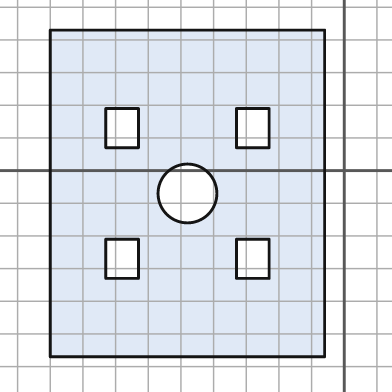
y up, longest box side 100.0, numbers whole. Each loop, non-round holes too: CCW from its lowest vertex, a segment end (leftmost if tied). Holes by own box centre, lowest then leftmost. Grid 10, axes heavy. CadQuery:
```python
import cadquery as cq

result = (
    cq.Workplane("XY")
    .moveTo(-90.0, -57.0)
    .lineTo(-6.0, -57.0)
    .lineTo(-6.0, 43.0)
    .lineTo(-90.0, 43.0)
    .close()
    .moveTo(-73.0, -33.0)
    .lineTo(-63.0, -33.0)
    .lineTo(-63.0, -21.0)
    .lineTo(-73.0, -21.0)
    .close()
    .moveTo(-33.0, -33.0)
    .lineTo(-23.0, -33.0)
    .lineTo(-23.0, -21.0)
    .lineTo(-33.0, -21.0)
    .close()
    .moveTo(-48.0, -7.0)
    .circle(9.0)
    .moveTo(-73.0, 7.0)
    .lineTo(-63.0, 7.0)
    .lineTo(-63.0, 19.0)
    .lineTo(-73.0, 19.0)
    .close()
    .moveTo(-33.0, 7.0)
    .lineTo(-23.0, 7.0)
    .lineTo(-23.0, 19.0)
    .lineTo(-33.0, 19.0)
    .close()
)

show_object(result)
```